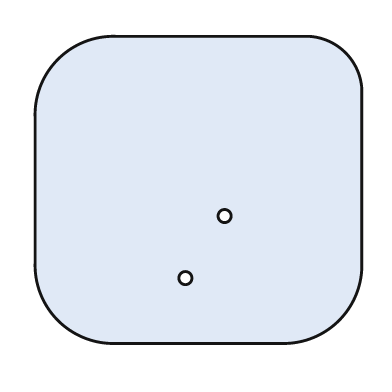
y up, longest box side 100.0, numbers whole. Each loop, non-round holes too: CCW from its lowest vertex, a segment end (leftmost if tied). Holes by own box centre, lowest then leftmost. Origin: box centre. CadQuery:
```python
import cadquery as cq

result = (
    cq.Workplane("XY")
    .moveTo(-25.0, -47.0)
    .lineTo(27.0, -47.0)
    .threePointArc((43.0, -40.0), (50.0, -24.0))
    .lineTo(50.0, 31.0)
    .threePointArc((45.0, 42.0), (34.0, 47.0))
    .lineTo(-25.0, 47.0)
    .threePointArc((-43.0, 40.0), (-50.0, 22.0))
    .lineTo(-50.0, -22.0)
    .threePointArc((-43.0, -40.0), (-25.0, -47.0))
    .close()
    .moveTo(-4.0, -27.0)
    .circle(2.0)
    .moveTo(8.0, -8.0)
    .circle(2.0)
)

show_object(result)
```